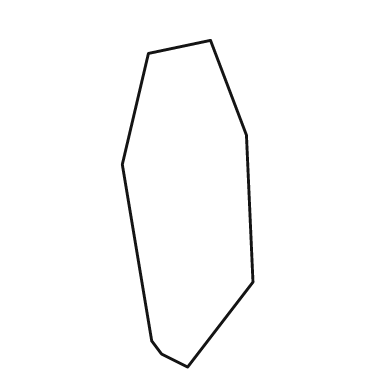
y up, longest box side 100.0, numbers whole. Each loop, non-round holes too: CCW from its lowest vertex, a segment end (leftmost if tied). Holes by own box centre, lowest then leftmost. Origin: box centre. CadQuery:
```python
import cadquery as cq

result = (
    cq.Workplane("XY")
    .moveTo(0.0, -50.0)
    .lineTo(20.0, -24.0)
    .lineTo(18.0, 21.0)
    .lineTo(7.0, 50.0)
    .lineTo(-12.0, 46.0)
    .lineTo(-20.0, 12.0)
    .lineTo(-11.0, -42.0)
    .lineTo(-8.0, -46.0)
    .close()
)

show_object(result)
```